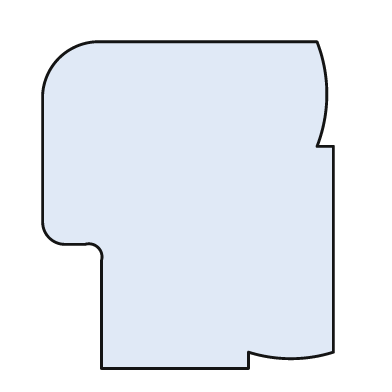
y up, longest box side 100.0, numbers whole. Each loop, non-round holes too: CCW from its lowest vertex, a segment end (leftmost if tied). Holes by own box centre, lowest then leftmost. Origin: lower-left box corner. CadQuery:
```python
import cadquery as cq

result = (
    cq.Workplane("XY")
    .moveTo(18.0, 0.0)
    .lineTo(63.0, 0.0)
    .lineTo(63.0, 5.0)
    .threePointArc((76.0, 3.0), (89.0, 5.0))
    .lineTo(89.0, 68.0)
    .lineTo(84.0, 68.0)
    .threePointArc((87.0, 84.0), (84.0, 100.0))
    .lineTo(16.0, 100.0)
    .threePointArc((5.0, 95.0), (0.0, 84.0))
    .lineTo(0.0, 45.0)
    .threePointArc((2.0, 40.0), (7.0, 38.0))
    .lineTo(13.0, 38.0)
    .threePointArc((17.0, 37.0), (18.0, 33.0))
    .close()
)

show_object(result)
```